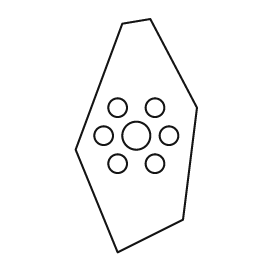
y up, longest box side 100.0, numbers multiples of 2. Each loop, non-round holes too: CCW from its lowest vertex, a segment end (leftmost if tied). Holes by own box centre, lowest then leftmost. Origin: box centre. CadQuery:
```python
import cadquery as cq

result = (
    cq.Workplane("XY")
    .moveTo(-8.0, -50.0)
    .lineTo(20.0, -36.0)
    .lineTo(26.0, 12.0)
    .lineTo(6.0, 50.0)
    .lineTo(-6.0, 48.0)
    .lineTo(-26.0, -6.0)
    .close()
    .moveTo(-8.0, -12.0)
    .circle(4.0)
    .moveTo(8.0, -12.0)
    .circle(4.0)
    .moveTo(-14.0, 0.0)
    .circle(4.0)
    .moveTo(0.0, 0.0)
    .circle(6.0)
    .moveTo(14.0, 0.0)
    .circle(4.0)
    .moveTo(-8.0, 12.0)
    .circle(4.0)
    .moveTo(8.0, 12.0)
    .circle(4.0)
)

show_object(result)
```